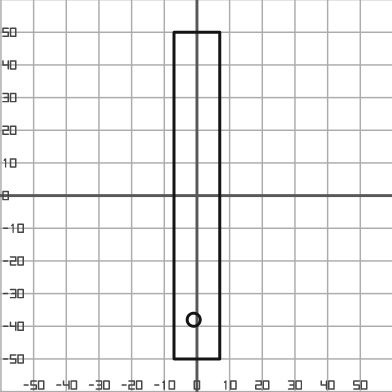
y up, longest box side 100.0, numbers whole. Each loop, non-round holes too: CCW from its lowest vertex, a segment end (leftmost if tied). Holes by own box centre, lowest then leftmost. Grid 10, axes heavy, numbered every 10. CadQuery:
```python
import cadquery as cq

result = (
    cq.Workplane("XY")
    .moveTo(-7.0, -50.0)
    .lineTo(7.0, -50.0)
    .lineTo(7.0, 50.0)
    .lineTo(-7.0, 50.0)
    .close()
    .moveTo(-1.0, -38.0)
    .circle(2.0)
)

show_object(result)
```